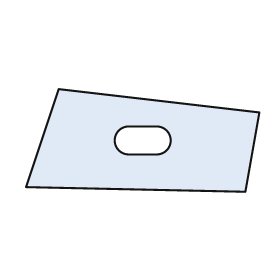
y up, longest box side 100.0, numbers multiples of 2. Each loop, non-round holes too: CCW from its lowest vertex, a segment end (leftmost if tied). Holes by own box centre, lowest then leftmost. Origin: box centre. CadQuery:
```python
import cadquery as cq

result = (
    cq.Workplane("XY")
    .moveTo(44.0, -22.0)
    .lineTo(50.0, 12.0)
    .lineTo(-36.0, 22.0)
    .lineTo(-50.0, -20.0)
    .close()
    .moveTo(-6.0, -6.0)
    .lineTo(6.0, -6.0)
    .threePointArc((12.0, 0.0), (6.0, 6.0))
    .lineTo(-6.0, 6.0)
    .threePointArc((-12.0, 0.0), (-6.0, -6.0))
    .close()
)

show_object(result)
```